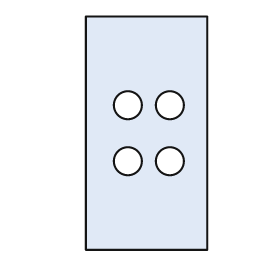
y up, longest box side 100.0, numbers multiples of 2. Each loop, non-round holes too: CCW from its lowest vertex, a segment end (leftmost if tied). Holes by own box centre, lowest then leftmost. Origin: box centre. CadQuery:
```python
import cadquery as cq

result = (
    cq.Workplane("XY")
    .moveTo(-26.0, -50.0)
    .lineTo(26.0, -50.0)
    .lineTo(26.0, 50.0)
    .lineTo(-26.0, 50.0)
    .close()
    .moveTo(-8.0, -12.0)
    .circle(6.0)
    .moveTo(10.0, -12.0)
    .circle(6.0)
    .moveTo(-8.0, 12.0)
    .circle(6.0)
    .moveTo(10.0, 12.0)
    .circle(6.0)
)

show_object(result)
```